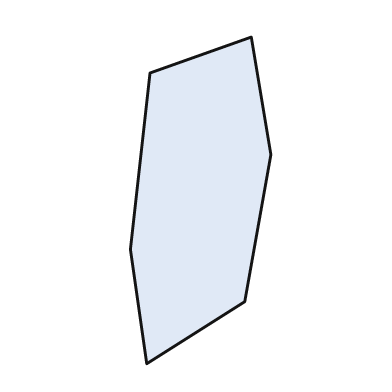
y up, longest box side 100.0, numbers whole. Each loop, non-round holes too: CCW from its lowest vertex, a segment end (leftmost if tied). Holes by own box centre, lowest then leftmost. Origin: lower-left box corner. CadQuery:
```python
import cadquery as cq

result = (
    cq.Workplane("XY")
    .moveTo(5.0, 0.0)
    .lineTo(35.0, 19.0)
    .lineTo(43.0, 64.0)
    .lineTo(37.0, 100.0)
    .lineTo(6.0, 89.0)
    .lineTo(0.0, 35.0)
    .close()
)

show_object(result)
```